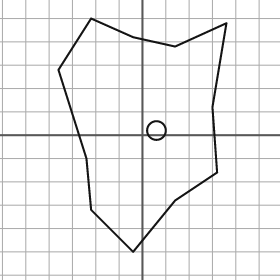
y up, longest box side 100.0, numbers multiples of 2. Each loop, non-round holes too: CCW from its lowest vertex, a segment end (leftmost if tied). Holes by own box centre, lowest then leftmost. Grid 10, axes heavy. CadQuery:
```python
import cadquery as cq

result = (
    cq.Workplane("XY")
    .moveTo(-4.0, -50.0)
    .lineTo(14.0, -28.0)
    .lineTo(32.0, -16.0)
    .lineTo(30.0, 12.0)
    .lineTo(36.0, 48.0)
    .lineTo(14.0, 38.0)
    .lineTo(-4.0, 42.0)
    .lineTo(-22.0, 50.0)
    .lineTo(-36.0, 28.0)
    .lineTo(-24.0, -10.0)
    .lineTo(-22.0, -32.0)
    .close()
    .moveTo(6.0, 2.0)
    .circle(4.0)
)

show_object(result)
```